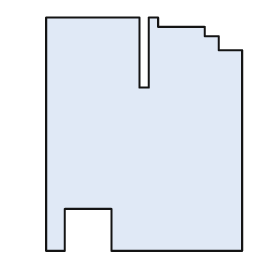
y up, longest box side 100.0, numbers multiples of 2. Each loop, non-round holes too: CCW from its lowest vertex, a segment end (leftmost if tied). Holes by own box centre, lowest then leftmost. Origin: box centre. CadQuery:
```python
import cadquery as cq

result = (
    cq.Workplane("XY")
    .moveTo(-42.0, -50.0)
    .lineTo(-34.0, -50.0)
    .lineTo(-34.0, -32.0)
    .lineTo(-14.0, -32.0)
    .lineTo(-14.0, -50.0)
    .lineTo(42.0, -50.0)
    .lineTo(42.0, 36.0)
    .lineTo(32.0, 36.0)
    .lineTo(32.0, 42.0)
    .lineTo(26.0, 42.0)
    .lineTo(26.0, 46.0)
    .lineTo(6.0, 46.0)
    .lineTo(6.0, 50.0)
    .lineTo(2.0, 50.0)
    .lineTo(2.0, 20.0)
    .lineTo(-2.0, 20.0)
    .lineTo(-2.0, 50.0)
    .lineTo(-42.0, 50.0)
    .close()
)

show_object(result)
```